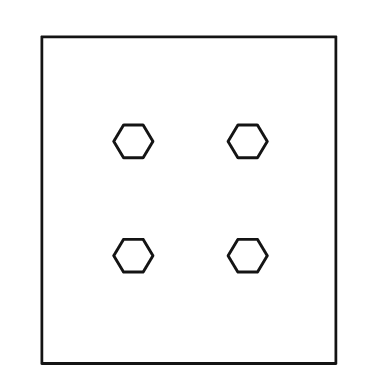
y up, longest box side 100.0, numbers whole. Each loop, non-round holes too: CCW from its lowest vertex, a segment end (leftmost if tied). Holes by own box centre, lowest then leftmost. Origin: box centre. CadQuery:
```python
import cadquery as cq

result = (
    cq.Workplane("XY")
    .moveTo(-45.0, -50.0)
    .lineTo(45.0, -50.0)
    .lineTo(45.0, 50.0)
    .lineTo(-45.0, 50.0)
    .close()
    .moveTo(-20.0, -22.0)
    .lineTo(-14.0, -22.0)
    .lineTo(-11.0, -17.0)
    .lineTo(-14.0, -12.0)
    .lineTo(-20.0, -12.0)
    .lineTo(-23.0, -17.0)
    .close()
    .moveTo(15.0, -22.0)
    .lineTo(21.0, -22.0)
    .lineTo(24.0, -17.0)
    .lineTo(21.0, -12.0)
    .lineTo(15.0, -12.0)
    .lineTo(12.0, -17.0)
    .close()
    .moveTo(-20.0, 13.0)
    .lineTo(-14.0, 13.0)
    .lineTo(-11.0, 18.0)
    .lineTo(-14.0, 23.0)
    .lineTo(-20.0, 23.0)
    .lineTo(-23.0, 18.0)
    .close()
    .moveTo(15.0, 13.0)
    .lineTo(21.0, 13.0)
    .lineTo(24.0, 18.0)
    .lineTo(21.0, 23.0)
    .lineTo(15.0, 23.0)
    .lineTo(12.0, 18.0)
    .close()
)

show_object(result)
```